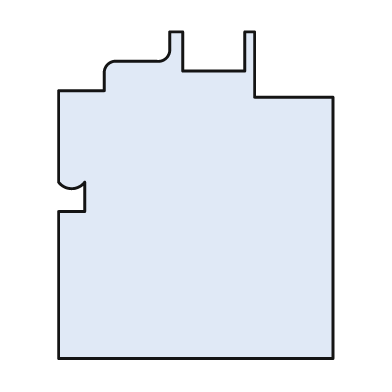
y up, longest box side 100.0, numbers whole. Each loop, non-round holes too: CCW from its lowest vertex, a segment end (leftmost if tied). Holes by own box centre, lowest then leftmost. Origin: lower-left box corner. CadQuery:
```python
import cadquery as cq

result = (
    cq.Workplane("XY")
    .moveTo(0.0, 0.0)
    .lineTo(84.0, 0.0)
    .lineTo(84.0, 80.0)
    .lineTo(60.0, 80.0)
    .lineTo(60.0, 100.0)
    .lineTo(57.0, 100.0)
    .lineTo(57.0, 88.0)
    .lineTo(38.0, 88.0)
    .lineTo(38.0, 100.0)
    .lineTo(34.0, 100.0)
    .lineTo(34.0, 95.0)
    .threePointArc((33.0, 92.0), (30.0, 91.0))
    .lineTo(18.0, 91.0)
    .threePointArc((15.0, 90.0), (14.0, 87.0))
    .lineTo(14.0, 82.0)
    .lineTo(0.0, 82.0)
    .lineTo(0.0, 54.0)
    .threePointArc((4.0, 52.0), (8.0, 54.0))
    .lineTo(8.0, 45.0)
    .lineTo(0.0, 45.0)
    .close()
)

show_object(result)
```